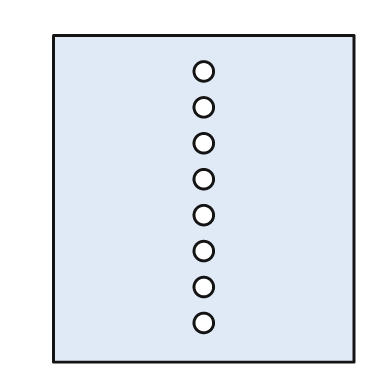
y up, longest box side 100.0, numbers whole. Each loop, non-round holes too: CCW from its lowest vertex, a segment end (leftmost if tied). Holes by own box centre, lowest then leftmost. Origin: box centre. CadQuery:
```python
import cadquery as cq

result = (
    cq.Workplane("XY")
    .moveTo(-46.0, -50.0)
    .lineTo(46.0, -50.0)
    .lineTo(46.0, 50.0)
    .lineTo(-46.0, 50.0)
    .close()
    .moveTo(0.0, -38.0)
    .circle(3.0)
    .moveTo(0.0, -27.0)
    .circle(3.0)
    .moveTo(0.0, -16.0)
    .circle(3.0)
    .moveTo(0.0, -5.0)
    .circle(3.0)
    .moveTo(0.0, 6.0)
    .circle(3.0)
    .moveTo(0.0, 17.0)
    .circle(3.0)
    .moveTo(0.0, 28.0)
    .circle(3.0)
    .moveTo(0.0, 39.0)
    .circle(3.0)
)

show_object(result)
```